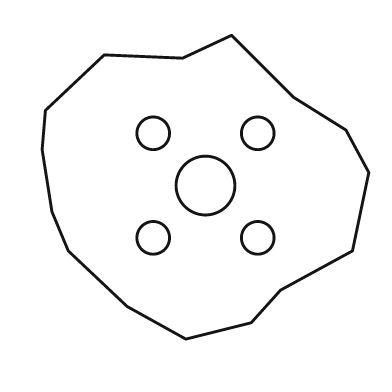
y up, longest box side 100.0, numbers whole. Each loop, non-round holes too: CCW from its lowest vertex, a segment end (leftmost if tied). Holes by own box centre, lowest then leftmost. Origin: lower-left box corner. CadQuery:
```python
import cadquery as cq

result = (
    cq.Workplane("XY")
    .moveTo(44.0, 0.0)
    .lineTo(64.0, 5.0)
    .lineTo(73.0, 15.0)
    .lineTo(95.0, 27.0)
    .lineTo(100.0, 51.0)
    .lineTo(93.0, 64.0)
    .lineTo(77.0, 74.0)
    .lineTo(58.0, 93.0)
    .lineTo(43.0, 86.0)
    .lineTo(19.0, 87.0)
    .lineTo(1.0, 70.0)
    .lineTo(0.0, 58.0)
    .lineTo(3.0, 39.0)
    .lineTo(8.0, 27.0)
    .lineTo(26.0, 10.0)
    .close()
    .moveTo(34.0, 31.0)
    .circle(5.0)
    .moveTo(66.0, 31.0)
    .circle(5.0)
    .moveTo(50.0, 47.0)
    .circle(9.0)
    .moveTo(34.0, 63.0)
    .circle(5.0)
    .moveTo(66.0, 63.0)
    .circle(5.0)
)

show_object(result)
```